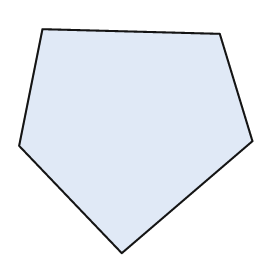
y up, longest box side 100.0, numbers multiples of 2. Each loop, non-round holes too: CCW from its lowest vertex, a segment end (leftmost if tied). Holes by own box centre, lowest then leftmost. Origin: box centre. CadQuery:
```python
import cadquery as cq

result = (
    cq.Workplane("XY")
    .moveTo(-6.0, -48.0)
    .lineTo(50.0, 0.0)
    .lineTo(36.0, 46.0)
    .lineTo(-40.0, 48.0)
    .lineTo(-50.0, -2.0)
    .close()
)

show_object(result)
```